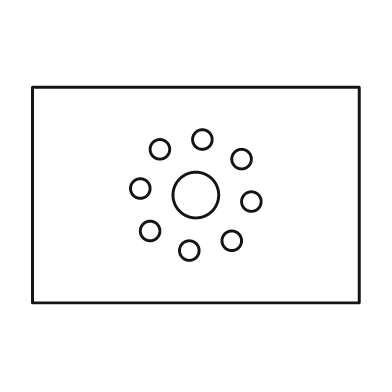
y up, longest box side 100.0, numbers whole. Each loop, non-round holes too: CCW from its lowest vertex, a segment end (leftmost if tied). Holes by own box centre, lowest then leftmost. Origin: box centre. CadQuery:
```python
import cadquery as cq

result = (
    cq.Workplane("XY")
    .moveTo(-50.0, -33.0)
    .lineTo(50.0, -33.0)
    .lineTo(50.0, 33.0)
    .lineTo(-50.0, 33.0)
    .close()
    .moveTo(-2.0, -17.0)
    .circle(3.0)
    .moveTo(11.0, -14.0)
    .circle(3.0)
    .moveTo(-14.0, -11.0)
    .circle(3.0)
    .moveTo(17.0, -2.0)
    .circle(3.0)
    .moveTo(0.0, 0.0)
    .circle(7.0)
    .moveTo(-17.0, 2.0)
    .circle(3.0)
    .moveTo(14.0, 11.0)
    .circle(3.0)
    .moveTo(-11.0, 14.0)
    .circle(3.0)
    .moveTo(2.0, 17.0)
    .circle(3.0)
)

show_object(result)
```